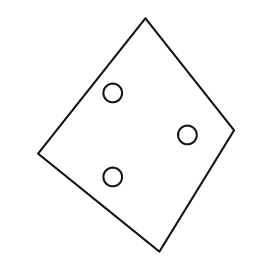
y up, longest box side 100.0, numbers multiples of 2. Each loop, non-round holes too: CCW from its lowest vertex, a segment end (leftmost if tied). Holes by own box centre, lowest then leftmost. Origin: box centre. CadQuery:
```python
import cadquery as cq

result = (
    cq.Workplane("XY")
    .moveTo(10.0, -50.0)
    .lineTo(42.0, 2.0)
    .lineTo(4.0, 50.0)
    .lineTo(-42.0, -8.0)
    .close()
    .moveTo(-10.0, -18.0)
    .circle(4.0)
    .moveTo(22.0, 0.0)
    .circle(4.0)
    .moveTo(-10.0, 18.0)
    .circle(4.0)
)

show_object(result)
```